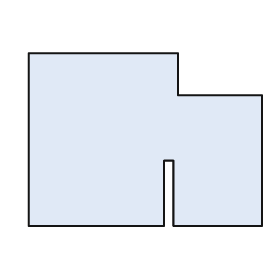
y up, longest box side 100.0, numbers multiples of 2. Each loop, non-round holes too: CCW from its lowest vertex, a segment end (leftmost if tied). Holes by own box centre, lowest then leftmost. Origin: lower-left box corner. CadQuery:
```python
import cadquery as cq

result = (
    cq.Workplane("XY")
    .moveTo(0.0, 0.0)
    .lineTo(58.0, 0.0)
    .lineTo(58.0, 28.0)
    .lineTo(62.0, 28.0)
    .lineTo(62.0, 0.0)
    .lineTo(100.0, 0.0)
    .lineTo(100.0, 56.0)
    .lineTo(64.0, 56.0)
    .lineTo(64.0, 74.0)
    .lineTo(0.0, 74.0)
    .close()
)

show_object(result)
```